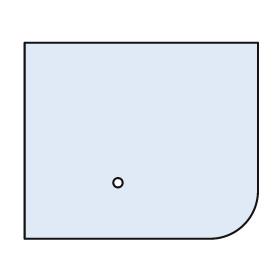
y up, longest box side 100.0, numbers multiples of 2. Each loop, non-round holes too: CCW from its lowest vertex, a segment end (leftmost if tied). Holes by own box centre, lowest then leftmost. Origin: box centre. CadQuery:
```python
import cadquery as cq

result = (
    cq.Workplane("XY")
    .moveTo(-50.0, -42.0)
    .lineTo(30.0, -42.0)
    .threePointArc((44.0, -36.0), (50.0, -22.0))
    .lineTo(50.0, 42.0)
    .lineTo(-50.0, 42.0)
    .close()
    .moveTo(-10.0, -18.0)
    .circle(2.0)
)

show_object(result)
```